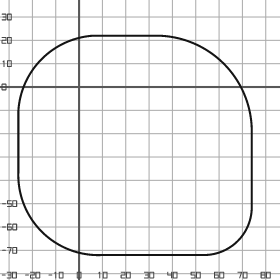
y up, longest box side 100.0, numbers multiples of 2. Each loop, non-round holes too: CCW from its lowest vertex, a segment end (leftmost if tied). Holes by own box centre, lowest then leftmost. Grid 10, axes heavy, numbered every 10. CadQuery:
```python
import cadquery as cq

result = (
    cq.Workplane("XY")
    .moveTo(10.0, -72.0)
    .lineTo(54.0, -72.0)
    .threePointArc((68.0, -66.0), (74.0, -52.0))
    .lineTo(74.0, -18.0)
    .threePointArc((62.0, 10.0), (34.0, 22.0))
    .lineTo(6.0, 22.0)
    .threePointArc((-16.0, 12.0), (-26.0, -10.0))
    .lineTo(-26.0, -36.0)
    .threePointArc((-16.0, -62.0), (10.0, -72.0))
    .close()
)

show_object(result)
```